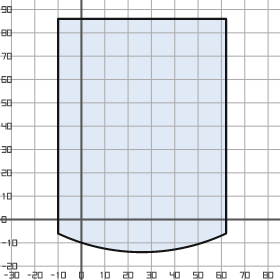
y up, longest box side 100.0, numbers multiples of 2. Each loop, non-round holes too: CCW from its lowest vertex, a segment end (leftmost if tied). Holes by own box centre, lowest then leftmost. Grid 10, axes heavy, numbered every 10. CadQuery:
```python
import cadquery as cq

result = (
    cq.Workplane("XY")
    .moveTo(-10.0, -6.0)
    .threePointArc((26.0, -14.0), (62.0, -6.0))
    .lineTo(62.0, 86.0)
    .lineTo(-10.0, 86.0)
    .close()
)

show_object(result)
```